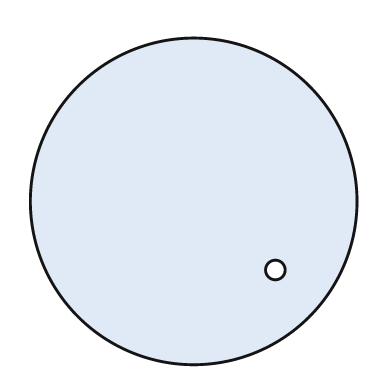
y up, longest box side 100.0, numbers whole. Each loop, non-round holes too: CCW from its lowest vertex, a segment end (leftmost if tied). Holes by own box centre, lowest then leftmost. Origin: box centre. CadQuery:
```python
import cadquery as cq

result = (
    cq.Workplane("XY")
    .moveTo(0.0, 0.0)
    .circle(50.0)
    .moveTo(25.0, -21.0)
    .circle(3.0)
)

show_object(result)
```